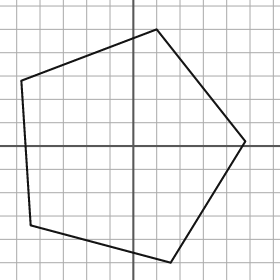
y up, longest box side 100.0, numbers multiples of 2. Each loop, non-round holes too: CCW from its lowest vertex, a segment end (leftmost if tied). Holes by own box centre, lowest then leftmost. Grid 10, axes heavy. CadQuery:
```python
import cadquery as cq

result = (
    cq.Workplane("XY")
    .moveTo(16.0, -50.0)
    .lineTo(48.0, 2.0)
    .lineTo(10.0, 50.0)
    .lineTo(-48.0, 28.0)
    .lineTo(-44.0, -34.0)
    .close()
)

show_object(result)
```